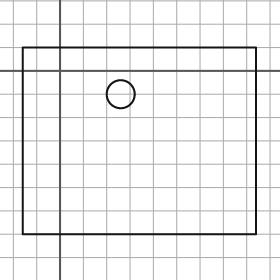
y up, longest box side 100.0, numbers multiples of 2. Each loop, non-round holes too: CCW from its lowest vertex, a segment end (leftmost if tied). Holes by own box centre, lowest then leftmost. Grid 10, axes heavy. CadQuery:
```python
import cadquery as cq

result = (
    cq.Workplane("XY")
    .moveTo(-16.0, -70.0)
    .lineTo(84.0, -70.0)
    .lineTo(84.0, 10.0)
    .lineTo(-16.0, 10.0)
    .close()
    .moveTo(26.0, -10.0)
    .circle(6.0)
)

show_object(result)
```